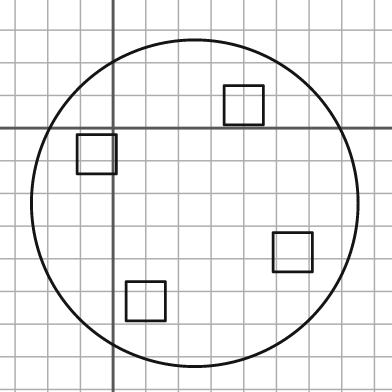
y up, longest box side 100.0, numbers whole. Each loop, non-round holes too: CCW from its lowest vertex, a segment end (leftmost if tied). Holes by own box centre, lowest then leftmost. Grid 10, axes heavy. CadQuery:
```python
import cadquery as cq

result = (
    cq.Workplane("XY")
    .moveTo(25.0, -23.0)
    .circle(50.0)
    .moveTo(4.0, -59.0)
    .lineTo(16.0, -59.0)
    .lineTo(16.0, -47.0)
    .lineTo(4.0, -47.0)
    .close()
    .moveTo(49.0, -44.0)
    .lineTo(61.0, -44.0)
    .lineTo(61.0, -32.0)
    .lineTo(49.0, -32.0)
    .close()
    .moveTo(-11.0, -14.0)
    .lineTo(1.0, -14.0)
    .lineTo(1.0, -2.0)
    .lineTo(-11.0, -2.0)
    .close()
    .moveTo(34.0, 1.0)
    .lineTo(46.0, 1.0)
    .lineTo(46.0, 13.0)
    .lineTo(34.0, 13.0)
    .close()
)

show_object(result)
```